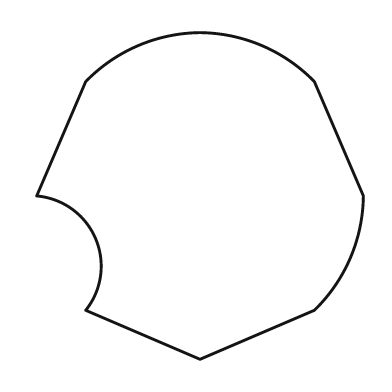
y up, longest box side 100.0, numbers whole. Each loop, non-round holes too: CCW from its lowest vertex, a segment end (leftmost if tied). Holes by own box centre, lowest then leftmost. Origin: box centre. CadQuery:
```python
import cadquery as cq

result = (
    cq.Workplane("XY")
    .moveTo(0.0, -50.0)
    .lineTo(35.0, -35.0)
    .threePointArc((46.0, -19.0), (50.0, 0.0))
    .lineTo(35.0, 35.0)
    .threePointArc((19.0, 46.0), (0.0, 50.0))
    .threePointArc((-19.0, 46.0), (-35.0, 35.0))
    .lineTo(-50.0, 0.0)
    .threePointArc((-32.0, -13.0), (-35.0, -35.0))
    .close()
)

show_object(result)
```